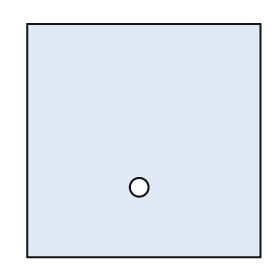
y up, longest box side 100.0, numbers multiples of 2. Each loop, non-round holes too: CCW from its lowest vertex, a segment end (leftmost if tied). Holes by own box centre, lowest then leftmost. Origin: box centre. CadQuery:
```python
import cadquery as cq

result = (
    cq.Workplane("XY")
    .moveTo(-50.0, -50.0)
    .lineTo(50.0, -50.0)
    .lineTo(50.0, 50.0)
    .lineTo(-50.0, 50.0)
    .close()
    .moveTo(-2.0, -20.0)
    .circle(4.0)
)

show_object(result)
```